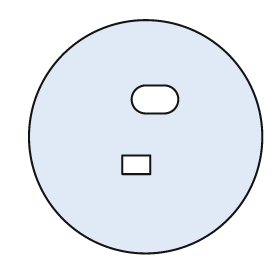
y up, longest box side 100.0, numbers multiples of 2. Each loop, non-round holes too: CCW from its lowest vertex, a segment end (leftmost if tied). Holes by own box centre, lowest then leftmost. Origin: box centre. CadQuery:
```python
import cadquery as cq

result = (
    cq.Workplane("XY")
    .moveTo(0.0, 0.0)
    .circle(50.0)
    .moveTo(-10.0, -16.0)
    .lineTo(2.0, -16.0)
    .lineTo(2.0, -8.0)
    .lineTo(-10.0, -8.0)
    .close()
    .moveTo(0.0, 10.0)
    .lineTo(8.0, 10.0)
    .threePointArc((14.0, 16.0), (8.0, 22.0))
    .lineTo(0.0, 22.0)
    .threePointArc((-6.0, 16.0), (0.0, 10.0))
    .close()
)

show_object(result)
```